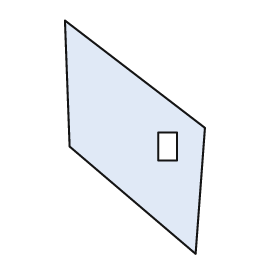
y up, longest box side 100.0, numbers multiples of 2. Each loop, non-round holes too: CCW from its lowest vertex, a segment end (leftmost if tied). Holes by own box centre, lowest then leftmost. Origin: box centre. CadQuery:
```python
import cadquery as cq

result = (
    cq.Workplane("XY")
    .moveTo(26.0, -50.0)
    .lineTo(30.0, 4.0)
    .lineTo(-30.0, 50.0)
    .lineTo(-28.0, -4.0)
    .close()
    .moveTo(10.0, -10.0)
    .lineTo(18.0, -10.0)
    .lineTo(18.0, 2.0)
    .lineTo(10.0, 2.0)
    .close()
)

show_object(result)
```